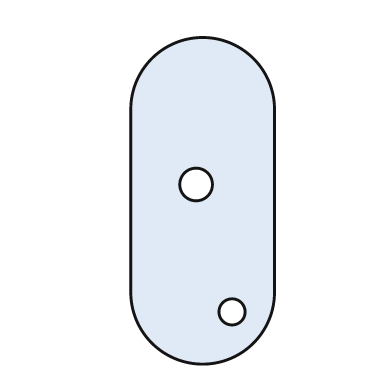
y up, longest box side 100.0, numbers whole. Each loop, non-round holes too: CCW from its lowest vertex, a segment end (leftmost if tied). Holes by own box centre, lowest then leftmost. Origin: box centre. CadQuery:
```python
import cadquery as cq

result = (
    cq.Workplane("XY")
    .moveTo(-22.0, -28.0)
    .threePointArc((0.0, -50.0), (22.0, -28.0))
    .lineTo(22.0, 28.0)
    .threePointArc((0.0, 50.0), (-22.0, 28.0))
    .close()
    .moveTo(9.0, -34.0)
    .circle(4.0)
    .moveTo(-2.0, 5.0)
    .circle(5.0)
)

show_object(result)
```